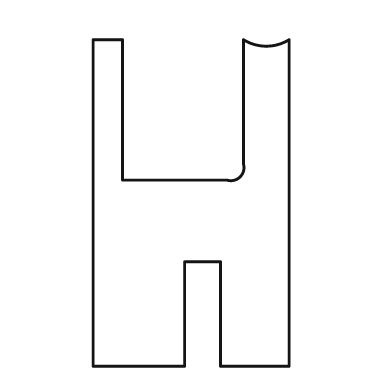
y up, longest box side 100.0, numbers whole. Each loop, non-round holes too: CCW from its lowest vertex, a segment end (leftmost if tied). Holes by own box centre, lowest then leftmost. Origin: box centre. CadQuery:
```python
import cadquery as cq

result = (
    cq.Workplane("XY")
    .moveTo(-30.0, -50.0)
    .lineTo(-2.0, -50.0)
    .lineTo(-2.0, -18.0)
    .lineTo(9.0, -18.0)
    .lineTo(9.0, -50.0)
    .lineTo(30.0, -50.0)
    .lineTo(30.0, 50.0)
    .threePointArc((23.0, 48.0), (16.0, 50.0))
    .lineTo(16.0, 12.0)
    .threePointArc((15.0, 8.0), (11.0, 7.0))
    .lineTo(-21.0, 7.0)
    .lineTo(-21.0, 50.0)
    .lineTo(-30.0, 50.0)
    .close()
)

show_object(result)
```